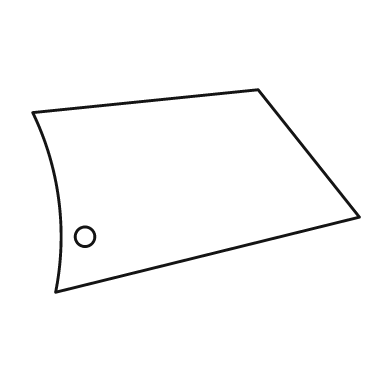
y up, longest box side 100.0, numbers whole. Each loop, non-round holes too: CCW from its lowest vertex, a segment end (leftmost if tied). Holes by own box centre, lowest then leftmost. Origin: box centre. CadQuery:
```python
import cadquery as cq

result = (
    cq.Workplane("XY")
    .moveTo(-43.0, -31.0)
    .lineTo(50.0, -8.0)
    .lineTo(19.0, 31.0)
    .lineTo(-50.0, 24.0)
    .threePointArc((-42.0, -3.0), (-43.0, -31.0))
    .close()
    .moveTo(-34.0, -14.0)
    .circle(3.0)
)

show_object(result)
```